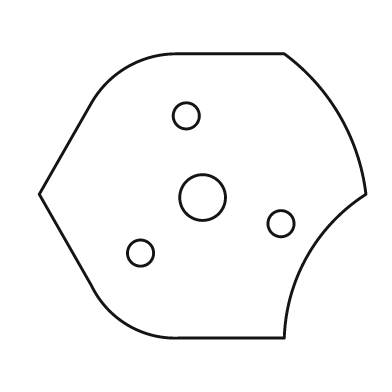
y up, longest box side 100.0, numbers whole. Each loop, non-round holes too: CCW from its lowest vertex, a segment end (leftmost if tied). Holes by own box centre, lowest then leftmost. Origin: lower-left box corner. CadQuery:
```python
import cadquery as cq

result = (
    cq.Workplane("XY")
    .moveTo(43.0, 0.0)
    .lineTo(75.0, 0.0)
    .threePointArc((82.0, 25.0), (100.0, 44.0))
    .threePointArc((92.0, 68.0), (75.0, 87.0))
    .lineTo(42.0, 87.0)
    .threePointArc((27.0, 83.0), (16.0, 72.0))
    .lineTo(0.0, 44.0)
    .lineTo(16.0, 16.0)
    .threePointArc((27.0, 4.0), (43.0, 0.0))
    .close()
    .moveTo(31.0, 26.0)
    .circle(4.0)
    .moveTo(74.0, 35.0)
    .circle(4.0)
    .moveTo(50.0, 43.0)
    .circle(7.0)
    .moveTo(45.0, 68.0)
    .circle(4.0)
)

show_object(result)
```